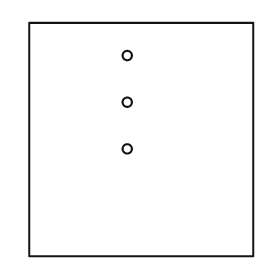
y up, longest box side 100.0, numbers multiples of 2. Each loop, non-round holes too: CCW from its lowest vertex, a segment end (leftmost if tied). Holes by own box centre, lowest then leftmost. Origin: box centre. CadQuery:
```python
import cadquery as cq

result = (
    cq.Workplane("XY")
    .moveTo(-48.0, -50.0)
    .lineTo(48.0, -50.0)
    .lineTo(48.0, 50.0)
    .lineTo(-48.0, 50.0)
    .close()
    .moveTo(-6.0, -4.0)
    .circle(2.0)
    .moveTo(-6.0, 16.0)
    .circle(2.0)
    .moveTo(-6.0, 36.0)
    .circle(2.0)
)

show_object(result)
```